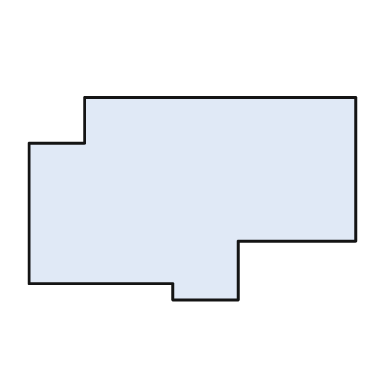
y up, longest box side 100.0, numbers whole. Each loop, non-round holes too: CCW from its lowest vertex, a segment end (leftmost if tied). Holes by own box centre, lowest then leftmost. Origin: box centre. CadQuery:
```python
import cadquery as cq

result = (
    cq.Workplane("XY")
    .moveTo(-6.0, -31.0)
    .lineTo(14.0, -31.0)
    .lineTo(14.0, -13.0)
    .lineTo(50.0, -13.0)
    .lineTo(50.0, 31.0)
    .lineTo(-33.0, 31.0)
    .lineTo(-33.0, 17.0)
    .lineTo(-50.0, 17.0)
    .lineTo(-50.0, -26.0)
    .lineTo(-6.0, -26.0)
    .close()
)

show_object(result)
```